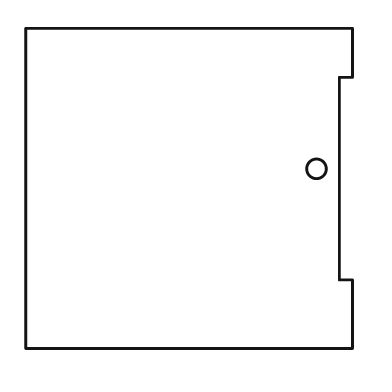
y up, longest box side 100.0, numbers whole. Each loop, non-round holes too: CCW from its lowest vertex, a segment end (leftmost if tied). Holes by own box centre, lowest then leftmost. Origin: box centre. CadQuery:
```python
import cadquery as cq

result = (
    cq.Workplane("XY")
    .moveTo(-50.0, -49.0)
    .lineTo(50.0, -49.0)
    .lineTo(50.0, -28.0)
    .lineTo(46.0, -28.0)
    .lineTo(46.0, 34.0)
    .lineTo(50.0, 34.0)
    .lineTo(50.0, 49.0)
    .lineTo(-50.0, 49.0)
    .close()
    .moveTo(39.0, 6.0)
    .circle(3.0)
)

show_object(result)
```